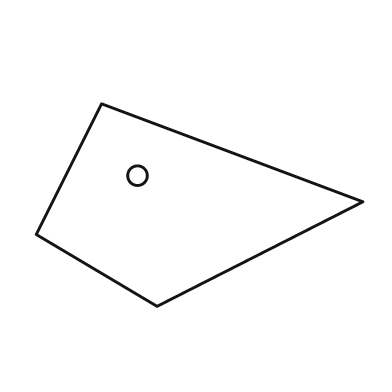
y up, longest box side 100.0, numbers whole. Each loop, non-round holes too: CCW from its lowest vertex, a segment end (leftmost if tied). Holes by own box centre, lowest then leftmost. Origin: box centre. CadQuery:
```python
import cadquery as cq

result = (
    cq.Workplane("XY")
    .moveTo(-13.0, -31.0)
    .lineTo(50.0, 1.0)
    .lineTo(-30.0, 31.0)
    .lineTo(-50.0, -9.0)
    .close()
    .moveTo(-19.0, 9.0)
    .circle(3.0)
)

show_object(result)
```